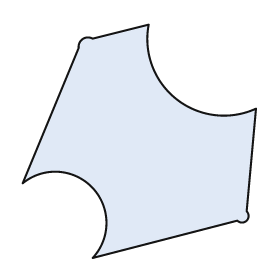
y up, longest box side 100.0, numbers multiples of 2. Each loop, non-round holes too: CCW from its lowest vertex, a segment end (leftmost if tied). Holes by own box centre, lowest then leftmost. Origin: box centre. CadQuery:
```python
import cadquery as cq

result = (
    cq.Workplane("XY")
    .moveTo(-20.0, -50.0)
    .lineTo(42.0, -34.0)
    .threePointArc((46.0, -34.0), (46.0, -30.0))
    .lineTo(50.0, 14.0)
    .threePointArc((16.0, 18.0), (4.0, 50.0))
    .lineTo(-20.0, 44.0)
    .threePointArc((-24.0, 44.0), (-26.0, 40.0))
    .lineTo(-50.0, -18.0)
    .threePointArc((-20.0, -20.0), (-20.0, -50.0))
    .close()
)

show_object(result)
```